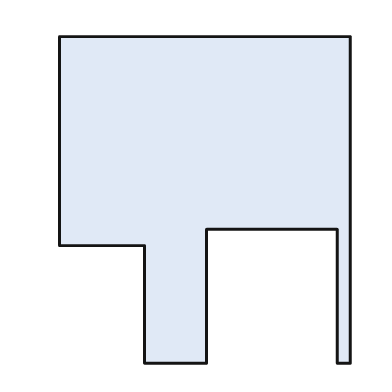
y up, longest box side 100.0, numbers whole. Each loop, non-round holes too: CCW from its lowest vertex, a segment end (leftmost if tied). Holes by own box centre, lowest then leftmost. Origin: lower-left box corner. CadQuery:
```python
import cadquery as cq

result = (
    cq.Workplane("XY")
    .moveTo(26.0, 0.0)
    .lineTo(45.0, 0.0)
    .lineTo(45.0, 41.0)
    .lineTo(85.0, 41.0)
    .lineTo(85.0, 0.0)
    .lineTo(89.0, 0.0)
    .lineTo(89.0, 100.0)
    .lineTo(0.0, 100.0)
    .lineTo(0.0, 36.0)
    .lineTo(26.0, 36.0)
    .close()
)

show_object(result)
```